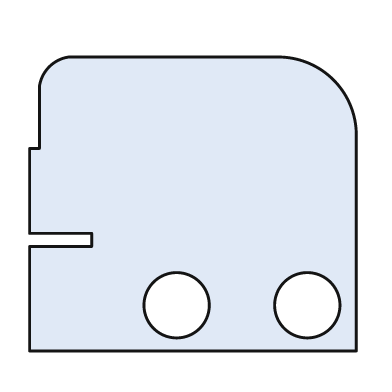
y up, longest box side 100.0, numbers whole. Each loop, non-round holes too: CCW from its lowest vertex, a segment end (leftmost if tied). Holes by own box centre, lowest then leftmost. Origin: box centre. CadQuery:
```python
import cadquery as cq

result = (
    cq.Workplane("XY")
    .moveTo(-50.0, -45.0)
    .lineTo(50.0, -45.0)
    .lineTo(50.0, 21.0)
    .threePointArc((43.0, 38.0), (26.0, 45.0))
    .lineTo(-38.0, 45.0)
    .threePointArc((-44.0, 42.0), (-47.0, 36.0))
    .lineTo(-47.0, 17.0)
    .lineTo(-50.0, 17.0)
    .lineTo(-50.0, -9.0)
    .lineTo(-31.0, -9.0)
    .lineTo(-31.0, -13.0)
    .lineTo(-50.0, -13.0)
    .close()
    .moveTo(-5.0, -31.0)
    .circle(10.0)
    .moveTo(35.0, -31.0)
    .circle(10.0)
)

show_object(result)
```